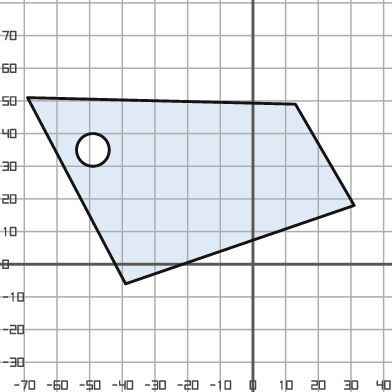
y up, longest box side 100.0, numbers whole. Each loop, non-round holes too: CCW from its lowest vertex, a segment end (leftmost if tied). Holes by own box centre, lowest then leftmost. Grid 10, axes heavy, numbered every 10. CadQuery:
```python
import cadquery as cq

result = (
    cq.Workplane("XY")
    .moveTo(-39.0, -6.0)
    .lineTo(31.0, 18.0)
    .lineTo(13.0, 49.0)
    .lineTo(-69.0, 51.0)
    .close()
    .moveTo(-49.0, 35.0)
    .circle(5.0)
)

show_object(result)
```